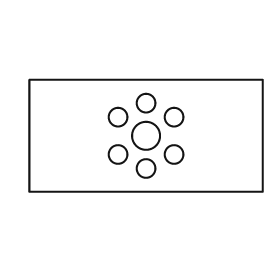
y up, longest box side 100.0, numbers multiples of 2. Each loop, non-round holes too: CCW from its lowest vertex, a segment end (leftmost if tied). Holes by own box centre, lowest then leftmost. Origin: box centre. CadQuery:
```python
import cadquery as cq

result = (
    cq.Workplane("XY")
    .moveTo(-50.0, -24.0)
    .lineTo(50.0, -24.0)
    .lineTo(50.0, 24.0)
    .lineTo(-50.0, 24.0)
    .close()
    .moveTo(0.0, -14.0)
    .circle(4.0)
    .moveTo(-12.0, -8.0)
    .circle(4.0)
    .moveTo(12.0, -8.0)
    .circle(4.0)
    .moveTo(0.0, 0.0)
    .circle(6.0)
    .moveTo(-12.0, 8.0)
    .circle(4.0)
    .moveTo(12.0, 8.0)
    .circle(4.0)
    .moveTo(0.0, 14.0)
    .circle(4.0)
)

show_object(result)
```